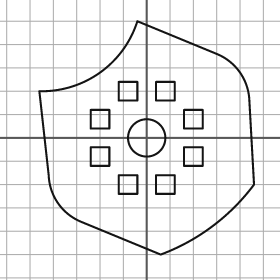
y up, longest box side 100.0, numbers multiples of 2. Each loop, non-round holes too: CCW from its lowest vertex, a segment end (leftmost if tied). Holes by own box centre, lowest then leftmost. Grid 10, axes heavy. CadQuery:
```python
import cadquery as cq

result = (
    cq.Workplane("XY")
    .moveTo(6.0, -50.0)
    .threePointArc((28.0, -38.0), (46.0, -20.0))
    .lineTo(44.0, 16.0)
    .threePointArc((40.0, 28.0), (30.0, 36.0))
    .lineTo(-4.0, 50.0)
    .threePointArc((-20.0, 28.0), (-46.0, 20.0))
    .lineTo(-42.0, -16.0)
    .threePointArc((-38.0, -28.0), (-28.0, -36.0))
    .close()
    .moveTo(-12.0, -24.0)
    .lineTo(-4.0, -24.0)
    .lineTo(-4.0, -16.0)
    .lineTo(-12.0, -16.0)
    .close()
    .moveTo(4.0, -24.0)
    .lineTo(12.0, -24.0)
    .lineTo(12.0, -16.0)
    .lineTo(4.0, -16.0)
    .close()
    .moveTo(-24.0, -12.0)
    .lineTo(-16.0, -12.0)
    .lineTo(-16.0, -4.0)
    .lineTo(-24.0, -4.0)
    .close()
    .moveTo(16.0, -12.0)
    .lineTo(24.0, -12.0)
    .lineTo(24.0, -4.0)
    .lineTo(16.0, -4.0)
    .close()
    .moveTo(0.0, 0.0)
    .circle(8.0)
    .moveTo(-24.0, 4.0)
    .lineTo(-16.0, 4.0)
    .lineTo(-16.0, 12.0)
    .lineTo(-24.0, 12.0)
    .close()
    .moveTo(16.0, 4.0)
    .lineTo(24.0, 4.0)
    .lineTo(24.0, 12.0)
    .lineTo(16.0, 12.0)
    .close()
    .moveTo(-12.0, 16.0)
    .lineTo(-4.0, 16.0)
    .lineTo(-4.0, 24.0)
    .lineTo(-12.0, 24.0)
    .close()
    .moveTo(4.0, 16.0)
    .lineTo(12.0, 16.0)
    .lineTo(12.0, 24.0)
    .lineTo(4.0, 24.0)
    .close()
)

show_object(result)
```